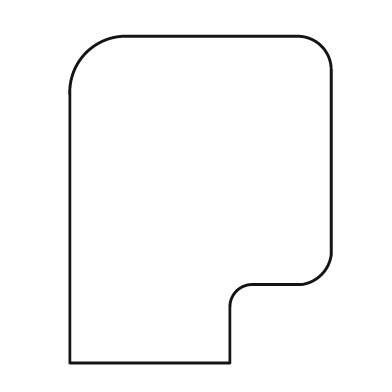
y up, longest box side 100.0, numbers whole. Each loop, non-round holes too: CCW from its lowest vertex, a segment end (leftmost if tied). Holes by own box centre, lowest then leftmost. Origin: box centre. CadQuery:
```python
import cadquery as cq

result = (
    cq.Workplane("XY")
    .moveTo(-40.0, -50.0)
    .lineTo(9.0, -50.0)
    .lineTo(9.0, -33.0)
    .threePointArc((11.0, -28.0), (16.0, -26.0))
    .lineTo(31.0, -26.0)
    .threePointArc((37.0, -23.0), (40.0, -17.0))
    .lineTo(40.0, 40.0)
    .threePointArc((37.0, 47.0), (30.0, 50.0))
    .lineTo(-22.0, 50.0)
    .threePointArc((-35.0, 45.0), (-40.0, 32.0))
    .close()
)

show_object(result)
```